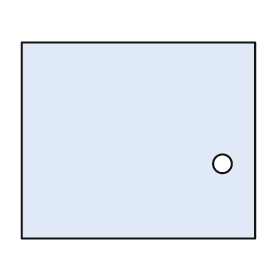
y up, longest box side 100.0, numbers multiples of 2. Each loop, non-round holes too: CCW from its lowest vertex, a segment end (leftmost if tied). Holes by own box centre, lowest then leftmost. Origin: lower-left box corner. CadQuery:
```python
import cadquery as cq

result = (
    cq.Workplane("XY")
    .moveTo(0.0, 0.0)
    .lineTo(100.0, 0.0)
    .lineTo(100.0, 84.0)
    .lineTo(0.0, 84.0)
    .close()
    .moveTo(86.0, 32.0)
    .circle(4.0)
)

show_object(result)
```